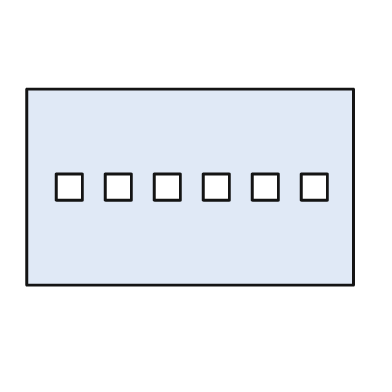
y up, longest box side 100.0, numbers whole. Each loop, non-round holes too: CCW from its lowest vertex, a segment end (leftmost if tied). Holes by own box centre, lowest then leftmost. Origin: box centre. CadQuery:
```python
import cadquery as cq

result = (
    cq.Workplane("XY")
    .moveTo(-50.0, -30.0)
    .lineTo(50.0, -30.0)
    .lineTo(50.0, 30.0)
    .lineTo(-50.0, 30.0)
    .close()
    .moveTo(-41.0, -4.0)
    .lineTo(-33.0, -4.0)
    .lineTo(-33.0, 4.0)
    .lineTo(-41.0, 4.0)
    .close()
    .moveTo(-26.0, -4.0)
    .lineTo(-18.0, -4.0)
    .lineTo(-18.0, 4.0)
    .lineTo(-26.0, 4.0)
    .close()
    .moveTo(-11.0, -4.0)
    .lineTo(-3.0, -4.0)
    .lineTo(-3.0, 4.0)
    .lineTo(-11.0, 4.0)
    .close()
    .moveTo(4.0, -4.0)
    .lineTo(12.0, -4.0)
    .lineTo(12.0, 4.0)
    .lineTo(4.0, 4.0)
    .close()
    .moveTo(19.0, -4.0)
    .lineTo(27.0, -4.0)
    .lineTo(27.0, 4.0)
    .lineTo(19.0, 4.0)
    .close()
    .moveTo(34.0, -4.0)
    .lineTo(42.0, -4.0)
    .lineTo(42.0, 4.0)
    .lineTo(34.0, 4.0)
    .close()
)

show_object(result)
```